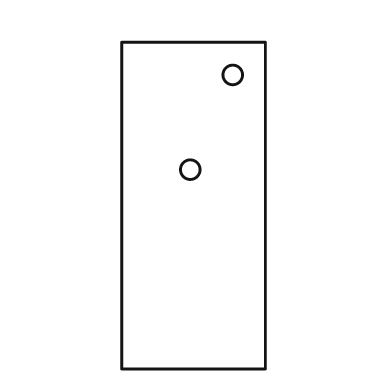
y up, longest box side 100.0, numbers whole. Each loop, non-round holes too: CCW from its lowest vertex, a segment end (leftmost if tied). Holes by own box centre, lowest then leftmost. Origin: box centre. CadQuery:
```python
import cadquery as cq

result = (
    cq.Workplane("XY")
    .moveTo(-22.0, -50.0)
    .lineTo(22.0, -50.0)
    .lineTo(22.0, 50.0)
    .lineTo(-22.0, 50.0)
    .close()
    .moveTo(-1.0, 11.0)
    .circle(3.0)
    .moveTo(12.0, 40.0)
    .circle(3.0)
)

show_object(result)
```